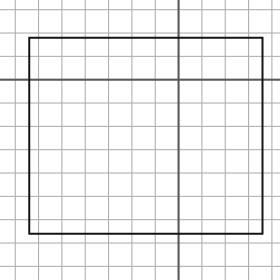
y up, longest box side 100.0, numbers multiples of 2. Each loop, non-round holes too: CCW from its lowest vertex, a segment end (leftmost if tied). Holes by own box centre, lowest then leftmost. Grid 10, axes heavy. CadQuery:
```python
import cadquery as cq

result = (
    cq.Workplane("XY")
    .moveTo(-64.0, -66.0)
    .lineTo(36.0, -66.0)
    .lineTo(36.0, 18.0)
    .lineTo(-64.0, 18.0)
    .close()
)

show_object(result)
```